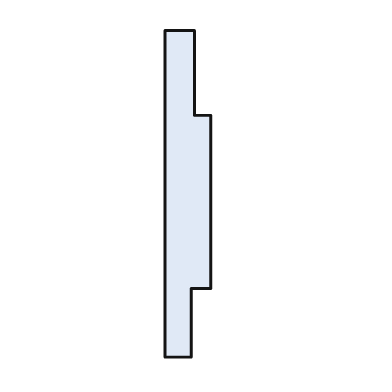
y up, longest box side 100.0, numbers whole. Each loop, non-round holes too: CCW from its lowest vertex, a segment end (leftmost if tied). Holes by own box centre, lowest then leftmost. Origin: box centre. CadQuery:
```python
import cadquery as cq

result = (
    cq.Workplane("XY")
    .moveTo(-7.0, -50.0)
    .lineTo(1.0, -50.0)
    .lineTo(1.0, -29.0)
    .lineTo(7.0, -29.0)
    .lineTo(7.0, 24.0)
    .lineTo(2.0, 24.0)
    .lineTo(2.0, 50.0)
    .lineTo(-7.0, 50.0)
    .close()
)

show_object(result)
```